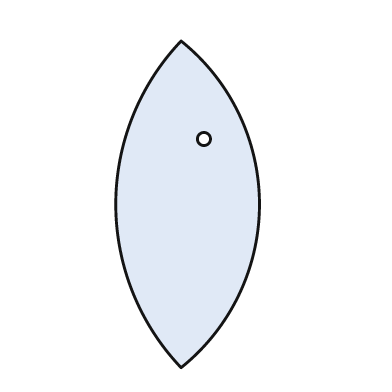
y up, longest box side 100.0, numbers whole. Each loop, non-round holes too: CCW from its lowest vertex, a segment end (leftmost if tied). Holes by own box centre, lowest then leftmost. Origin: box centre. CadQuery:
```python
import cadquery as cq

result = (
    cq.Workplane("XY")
    .moveTo(-2.0, -50.0)
    .threePointArc((22.0, 0.0), (-2.0, 50.0))
    .threePointArc((-22.0, 0.0), (-2.0, -50.0))
    .close()
    .moveTo(5.0, 20.0)
    .circle(2.0)
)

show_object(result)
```